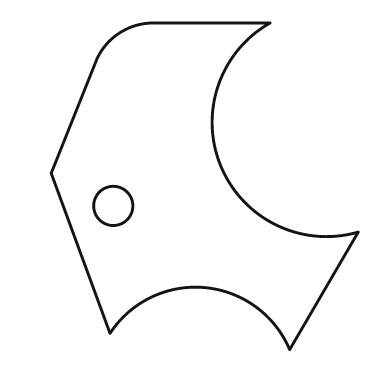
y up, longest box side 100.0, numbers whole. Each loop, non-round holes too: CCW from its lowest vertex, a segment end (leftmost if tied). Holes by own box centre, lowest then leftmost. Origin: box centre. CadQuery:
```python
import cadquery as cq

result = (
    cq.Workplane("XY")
    .moveTo(26.0, -50.0)
    .lineTo(47.0, -14.0)
    .threePointArc((5.0, 6.0), (20.0, 50.0))
    .lineTo(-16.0, 50.0)
    .threePointArc((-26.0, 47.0), (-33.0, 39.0))
    .lineTo(-47.0, 4.0)
    .lineTo(-29.0, -45.0)
    .threePointArc((0.0, -31.0), (26.0, -50.0))
    .close()
    .moveTo(-28.0, -6.0)
    .circle(6.0)
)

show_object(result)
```